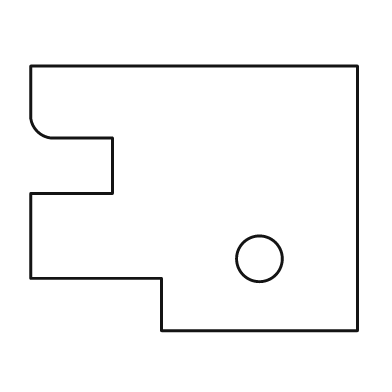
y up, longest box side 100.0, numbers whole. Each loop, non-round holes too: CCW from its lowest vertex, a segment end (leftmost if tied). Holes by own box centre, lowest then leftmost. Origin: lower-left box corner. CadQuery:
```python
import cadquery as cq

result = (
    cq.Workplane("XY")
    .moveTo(40.0, 0.0)
    .lineTo(100.0, 0.0)
    .lineTo(100.0, 81.0)
    .lineTo(0.0, 81.0)
    .lineTo(0.0, 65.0)
    .threePointArc((2.0, 61.0), (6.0, 59.0))
    .lineTo(25.0, 59.0)
    .lineTo(25.0, 42.0)
    .lineTo(0.0, 42.0)
    .lineTo(0.0, 16.0)
    .lineTo(40.0, 16.0)
    .close()
    .moveTo(70.0, 22.0)
    .circle(7.0)
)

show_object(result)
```